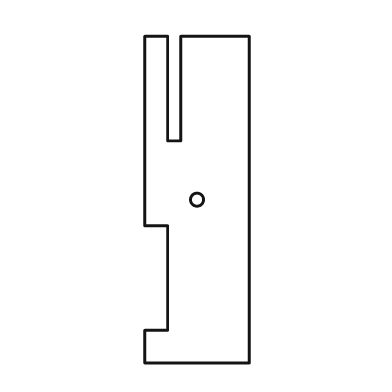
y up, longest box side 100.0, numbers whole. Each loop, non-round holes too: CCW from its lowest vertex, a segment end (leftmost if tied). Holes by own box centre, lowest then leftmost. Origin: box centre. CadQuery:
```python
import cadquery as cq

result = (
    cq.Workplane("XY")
    .moveTo(-16.0, -50.0)
    .lineTo(16.0, -50.0)
    .lineTo(16.0, 50.0)
    .lineTo(-5.0, 50.0)
    .lineTo(-5.0, 18.0)
    .lineTo(-9.0, 18.0)
    .lineTo(-9.0, 50.0)
    .lineTo(-16.0, 50.0)
    .lineTo(-16.0, -8.0)
    .lineTo(-9.0, -8.0)
    .lineTo(-9.0, -40.0)
    .lineTo(-16.0, -40.0)
    .close()
    .moveTo(0.0, 0.0)
    .circle(2.0)
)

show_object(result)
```